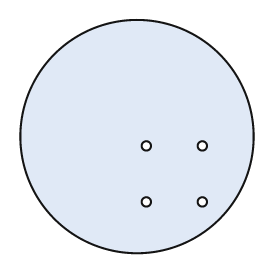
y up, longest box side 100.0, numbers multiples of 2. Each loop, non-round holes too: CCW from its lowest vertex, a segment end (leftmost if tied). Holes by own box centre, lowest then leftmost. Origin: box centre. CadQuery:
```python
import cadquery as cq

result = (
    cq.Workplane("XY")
    .moveTo(0.0, 0.0)
    .circle(50.0)
    .moveTo(4.0, -28.0)
    .circle(2.0)
    .moveTo(28.0, -28.0)
    .circle(2.0)
    .moveTo(4.0, -4.0)
    .circle(2.0)
    .moveTo(28.0, -4.0)
    .circle(2.0)
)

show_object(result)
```